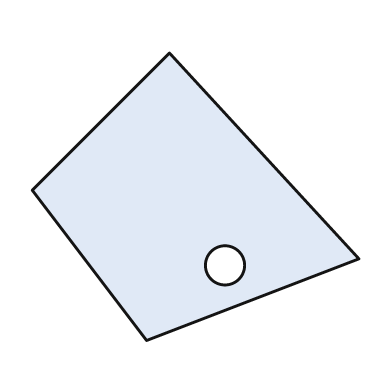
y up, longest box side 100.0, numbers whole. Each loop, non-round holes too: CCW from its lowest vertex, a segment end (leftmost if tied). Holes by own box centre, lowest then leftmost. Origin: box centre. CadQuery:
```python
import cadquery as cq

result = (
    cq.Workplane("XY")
    .moveTo(-15.0, -44.0)
    .lineTo(50.0, -19.0)
    .lineTo(-8.0, 44.0)
    .lineTo(-50.0, 2.0)
    .close()
    .moveTo(9.0, -21.0)
    .circle(6.0)
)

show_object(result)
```